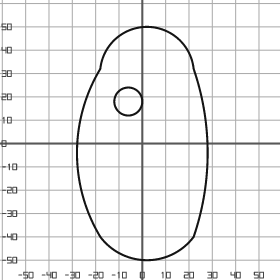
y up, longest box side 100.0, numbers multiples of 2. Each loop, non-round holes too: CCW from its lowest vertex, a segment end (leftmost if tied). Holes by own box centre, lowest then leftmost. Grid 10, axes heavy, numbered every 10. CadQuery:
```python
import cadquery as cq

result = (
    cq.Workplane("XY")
    .moveTo(-18.0, -40.0)
    .threePointArc((2.0, -50.0), (22.0, -40.0))
    .threePointArc((28.0, -4.0), (22.0, 32.0))
    .threePointArc((2.0, 50.0), (-18.0, 32.0))
    .threePointArc((-28.0, -4.0), (-18.0, -40.0))
    .close()
    .moveTo(-6.0, 18.0)
    .circle(6.0)
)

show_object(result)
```